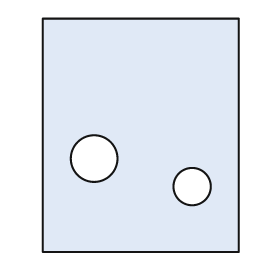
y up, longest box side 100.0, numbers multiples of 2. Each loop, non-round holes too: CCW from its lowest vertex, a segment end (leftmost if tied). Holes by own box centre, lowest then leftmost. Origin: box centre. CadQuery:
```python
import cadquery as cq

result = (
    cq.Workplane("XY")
    .moveTo(-42.0, -50.0)
    .lineTo(42.0, -50.0)
    .lineTo(42.0, 50.0)
    .lineTo(-42.0, 50.0)
    .close()
    .moveTo(22.0, -22.0)
    .circle(8.0)
    .moveTo(-20.0, -10.0)
    .circle(10.0)
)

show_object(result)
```